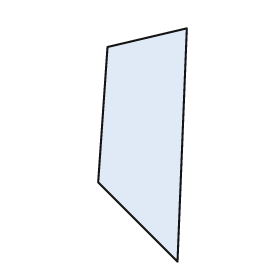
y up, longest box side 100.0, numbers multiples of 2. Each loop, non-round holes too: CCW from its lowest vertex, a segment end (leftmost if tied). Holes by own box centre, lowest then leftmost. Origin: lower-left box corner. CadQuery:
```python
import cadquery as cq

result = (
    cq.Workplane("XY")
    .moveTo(34.0, 0.0)
    .lineTo(38.0, 100.0)
    .lineTo(4.0, 92.0)
    .lineTo(0.0, 34.0)
    .close()
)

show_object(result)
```